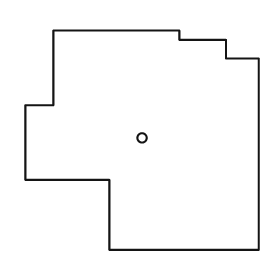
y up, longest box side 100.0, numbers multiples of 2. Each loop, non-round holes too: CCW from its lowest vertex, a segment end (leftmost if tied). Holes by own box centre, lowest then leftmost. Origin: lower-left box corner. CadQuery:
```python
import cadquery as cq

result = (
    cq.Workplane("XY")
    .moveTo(36.0, 0.0)
    .lineTo(100.0, 0.0)
    .lineTo(100.0, 82.0)
    .lineTo(86.0, 82.0)
    .lineTo(86.0, 90.0)
    .lineTo(66.0, 90.0)
    .lineTo(66.0, 94.0)
    .lineTo(12.0, 94.0)
    .lineTo(12.0, 62.0)
    .lineTo(0.0, 62.0)
    .lineTo(0.0, 30.0)
    .lineTo(36.0, 30.0)
    .close()
    .moveTo(50.0, 48.0)
    .circle(2.0)
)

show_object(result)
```